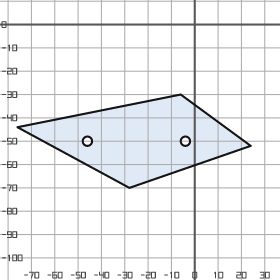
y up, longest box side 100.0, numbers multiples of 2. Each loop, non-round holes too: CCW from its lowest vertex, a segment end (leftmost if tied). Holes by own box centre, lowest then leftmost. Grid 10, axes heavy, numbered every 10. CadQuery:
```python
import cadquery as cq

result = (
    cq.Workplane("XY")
    .moveTo(-28.0, -70.0)
    .lineTo(24.0, -52.0)
    .lineTo(-6.0, -30.0)
    .lineTo(-76.0, -44.0)
    .close()
    .moveTo(-46.0, -50.0)
    .circle(2.0)
    .moveTo(-4.0, -50.0)
    .circle(2.0)
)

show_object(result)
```